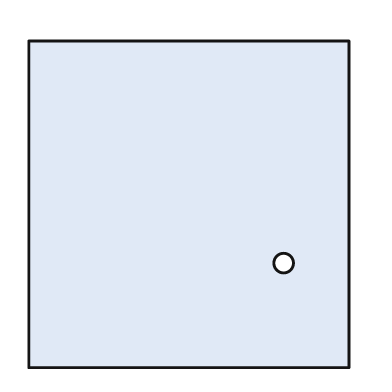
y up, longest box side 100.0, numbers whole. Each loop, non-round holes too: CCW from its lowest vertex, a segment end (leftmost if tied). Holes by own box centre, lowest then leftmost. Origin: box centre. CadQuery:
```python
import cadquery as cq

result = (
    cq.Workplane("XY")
    .moveTo(-49.0, -50.0)
    .lineTo(49.0, -50.0)
    .lineTo(49.0, 50.0)
    .lineTo(-49.0, 50.0)
    .close()
    .moveTo(29.0, -18.0)
    .circle(3.0)
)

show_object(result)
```